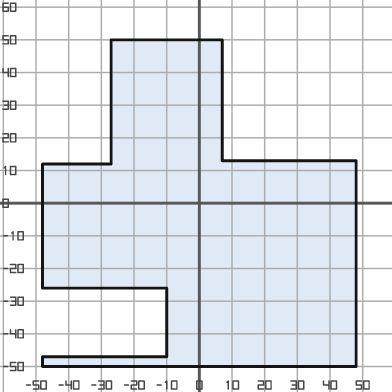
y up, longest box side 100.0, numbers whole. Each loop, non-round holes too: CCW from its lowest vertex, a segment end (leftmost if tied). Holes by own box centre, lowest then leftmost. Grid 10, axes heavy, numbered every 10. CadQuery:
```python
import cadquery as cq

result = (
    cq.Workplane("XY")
    .moveTo(-48.0, -50.0)
    .lineTo(48.0, -50.0)
    .lineTo(48.0, 13.0)
    .lineTo(7.0, 13.0)
    .lineTo(7.0, 50.0)
    .lineTo(-27.0, 50.0)
    .lineTo(-27.0, 12.0)
    .lineTo(-48.0, 12.0)
    .lineTo(-48.0, -26.0)
    .lineTo(-10.0, -26.0)
    .lineTo(-10.0, -47.0)
    .lineTo(-48.0, -47.0)
    .close()
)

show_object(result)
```